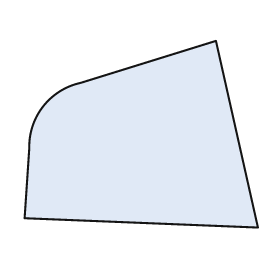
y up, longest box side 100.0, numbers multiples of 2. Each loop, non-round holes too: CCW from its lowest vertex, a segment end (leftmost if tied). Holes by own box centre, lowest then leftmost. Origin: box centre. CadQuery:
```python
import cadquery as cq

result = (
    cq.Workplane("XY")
    .moveTo(50.0, -40.0)
    .lineTo(32.0, 40.0)
    .lineTo(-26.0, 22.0)
    .threePointArc((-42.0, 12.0), (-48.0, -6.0))
    .lineTo(-50.0, -36.0)
    .close()
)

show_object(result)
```